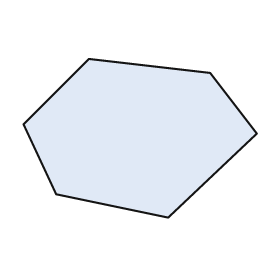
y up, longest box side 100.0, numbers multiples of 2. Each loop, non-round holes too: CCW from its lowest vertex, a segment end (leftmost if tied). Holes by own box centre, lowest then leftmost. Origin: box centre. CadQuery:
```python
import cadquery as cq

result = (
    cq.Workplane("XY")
    .moveTo(12.0, -34.0)
    .lineTo(50.0, 2.0)
    .lineTo(30.0, 28.0)
    .lineTo(-22.0, 34.0)
    .lineTo(-50.0, 6.0)
    .lineTo(-36.0, -24.0)
    .close()
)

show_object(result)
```